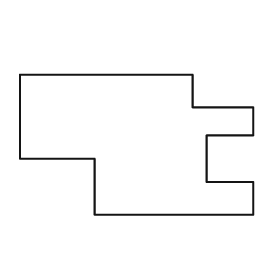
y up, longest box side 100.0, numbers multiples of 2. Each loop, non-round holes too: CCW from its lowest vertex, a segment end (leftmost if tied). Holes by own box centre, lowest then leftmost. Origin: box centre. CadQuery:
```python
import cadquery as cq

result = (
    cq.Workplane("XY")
    .moveTo(-18.0, -30.0)
    .lineTo(50.0, -30.0)
    .lineTo(50.0, -16.0)
    .lineTo(30.0, -16.0)
    .lineTo(30.0, 4.0)
    .lineTo(50.0, 4.0)
    .lineTo(50.0, 16.0)
    .lineTo(24.0, 16.0)
    .lineTo(24.0, 30.0)
    .lineTo(-50.0, 30.0)
    .lineTo(-50.0, -6.0)
    .lineTo(-18.0, -6.0)
    .close()
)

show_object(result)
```